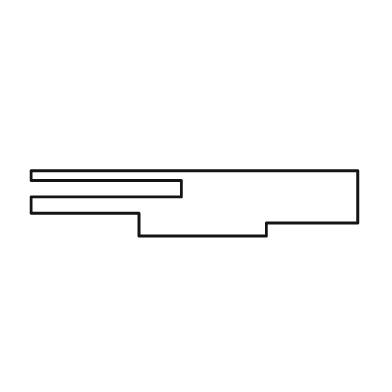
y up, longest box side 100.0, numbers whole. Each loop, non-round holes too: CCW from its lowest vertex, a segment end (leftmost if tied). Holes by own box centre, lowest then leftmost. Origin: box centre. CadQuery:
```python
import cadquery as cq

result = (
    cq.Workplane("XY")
    .moveTo(-17.0, -10.0)
    .lineTo(22.0, -10.0)
    .lineTo(22.0, -6.0)
    .lineTo(50.0, -6.0)
    .lineTo(50.0, 10.0)
    .lineTo(-50.0, 10.0)
    .lineTo(-50.0, 7.0)
    .lineTo(-4.0, 7.0)
    .lineTo(-4.0, 2.0)
    .lineTo(-50.0, 2.0)
    .lineTo(-50.0, -3.0)
    .lineTo(-17.0, -3.0)
    .close()
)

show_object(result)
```